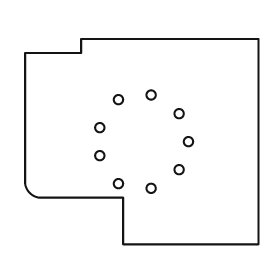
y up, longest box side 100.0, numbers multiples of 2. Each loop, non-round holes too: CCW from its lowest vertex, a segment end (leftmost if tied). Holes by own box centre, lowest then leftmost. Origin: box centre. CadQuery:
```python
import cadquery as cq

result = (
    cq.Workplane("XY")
    .moveTo(-8.0, -44.0)
    .lineTo(50.0, -44.0)
    .lineTo(50.0, 44.0)
    .lineTo(-26.0, 44.0)
    .lineTo(-26.0, 38.0)
    .lineTo(-50.0, 38.0)
    .lineTo(-50.0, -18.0)
    .threePointArc((-48.0, -22.0), (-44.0, -24.0))
    .lineTo(-8.0, -24.0)
    .close()
    .moveTo(4.0, -20.0)
    .circle(2.0)
    .moveTo(-10.0, -18.0)
    .circle(2.0)
    .moveTo(16.0, -12.0)
    .circle(2.0)
    .moveTo(-18.0, -6.0)
    .circle(2.0)
    .moveTo(20.0, 0.0)
    .circle(2.0)
    .moveTo(-18.0, 6.0)
    .circle(2.0)
    .moveTo(16.0, 12.0)
    .circle(2.0)
    .moveTo(-10.0, 18.0)
    .circle(2.0)
    .moveTo(4.0, 20.0)
    .circle(2.0)
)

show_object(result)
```